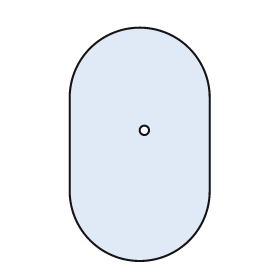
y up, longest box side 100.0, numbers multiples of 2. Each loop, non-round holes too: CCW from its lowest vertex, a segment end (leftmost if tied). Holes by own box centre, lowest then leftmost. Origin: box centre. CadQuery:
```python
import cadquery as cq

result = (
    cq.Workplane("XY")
    .moveTo(-30.0, -20.0)
    .threePointArc((0.0, -50.0), (30.0, -20.0))
    .lineTo(30.0, 20.0)
    .threePointArc((0.0, 50.0), (-30.0, 20.0))
    .close()
    .moveTo(2.0, 6.0)
    .circle(2.0)
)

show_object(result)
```